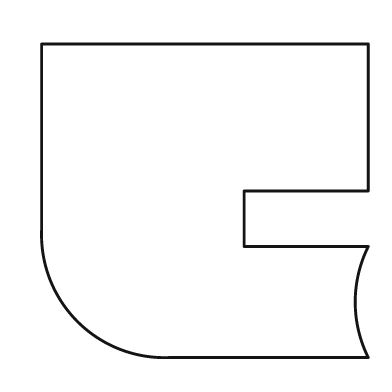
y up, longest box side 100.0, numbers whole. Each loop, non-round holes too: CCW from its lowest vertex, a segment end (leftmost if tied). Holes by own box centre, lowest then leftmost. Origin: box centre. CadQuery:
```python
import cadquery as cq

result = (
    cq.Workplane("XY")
    .moveTo(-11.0, -48.0)
    .lineTo(50.0, -48.0)
    .threePointArc((46.0, -31.0), (50.0, -14.0))
    .lineTo(12.0, -14.0)
    .lineTo(12.0, 3.0)
    .lineTo(50.0, 3.0)
    .lineTo(50.0, 48.0)
    .lineTo(-50.0, 48.0)
    .lineTo(-50.0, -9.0)
    .threePointArc((-39.0, -37.0), (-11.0, -48.0))
    .close()
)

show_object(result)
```